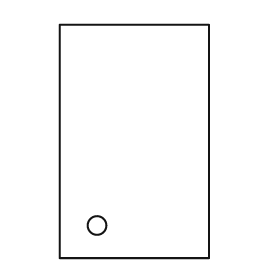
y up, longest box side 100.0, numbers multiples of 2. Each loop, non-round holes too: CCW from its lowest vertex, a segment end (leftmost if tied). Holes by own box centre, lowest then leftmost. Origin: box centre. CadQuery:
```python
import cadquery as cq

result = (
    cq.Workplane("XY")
    .moveTo(-32.0, -50.0)
    .lineTo(32.0, -50.0)
    .lineTo(32.0, 50.0)
    .lineTo(-32.0, 50.0)
    .close()
    .moveTo(-16.0, -36.0)
    .circle(4.0)
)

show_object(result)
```